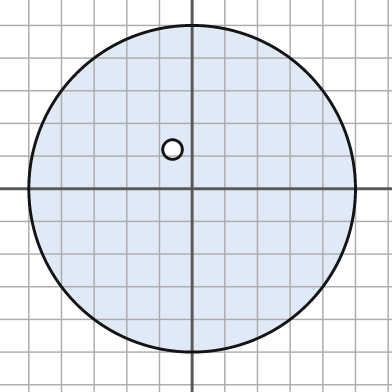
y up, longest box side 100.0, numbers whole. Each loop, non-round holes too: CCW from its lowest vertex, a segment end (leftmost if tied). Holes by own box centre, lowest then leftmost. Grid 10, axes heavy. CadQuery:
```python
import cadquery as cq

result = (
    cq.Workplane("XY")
    .moveTo(0.0, 0.0)
    .circle(50.0)
    .moveTo(-6.0, 12.0)
    .circle(3.0)
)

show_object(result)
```